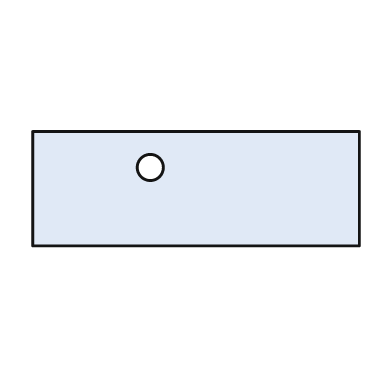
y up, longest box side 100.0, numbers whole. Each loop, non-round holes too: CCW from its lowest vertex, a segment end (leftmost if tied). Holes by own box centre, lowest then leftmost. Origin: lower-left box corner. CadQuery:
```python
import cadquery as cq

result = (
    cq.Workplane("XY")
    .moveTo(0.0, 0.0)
    .lineTo(100.0, 0.0)
    .lineTo(100.0, 35.0)
    .lineTo(0.0, 35.0)
    .close()
    .moveTo(36.0, 24.0)
    .circle(4.0)
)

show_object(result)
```